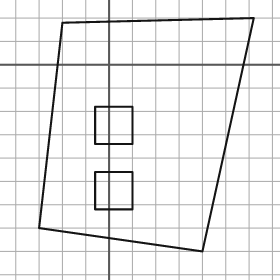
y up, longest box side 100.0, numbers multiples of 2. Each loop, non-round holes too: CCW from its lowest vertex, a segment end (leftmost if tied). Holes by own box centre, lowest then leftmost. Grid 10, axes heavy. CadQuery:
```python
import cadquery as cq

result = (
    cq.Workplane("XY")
    .moveTo(40.0, -80.0)
    .lineTo(62.0, 20.0)
    .lineTo(-20.0, 18.0)
    .lineTo(-30.0, -70.0)
    .close()
    .moveTo(-6.0, -62.0)
    .lineTo(10.0, -62.0)
    .lineTo(10.0, -46.0)
    .lineTo(-6.0, -46.0)
    .close()
    .moveTo(-6.0, -34.0)
    .lineTo(10.0, -34.0)
    .lineTo(10.0, -18.0)
    .lineTo(-6.0, -18.0)
    .close()
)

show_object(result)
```